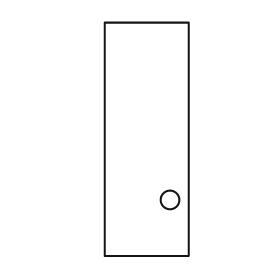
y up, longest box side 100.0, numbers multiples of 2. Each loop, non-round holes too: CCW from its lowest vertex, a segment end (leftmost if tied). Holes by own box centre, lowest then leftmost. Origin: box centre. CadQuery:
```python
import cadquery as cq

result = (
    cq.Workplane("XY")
    .moveTo(-18.0, -50.0)
    .lineTo(18.0, -50.0)
    .lineTo(18.0, 50.0)
    .lineTo(-18.0, 50.0)
    .close()
    .moveTo(10.0, -26.0)
    .circle(4.0)
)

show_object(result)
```